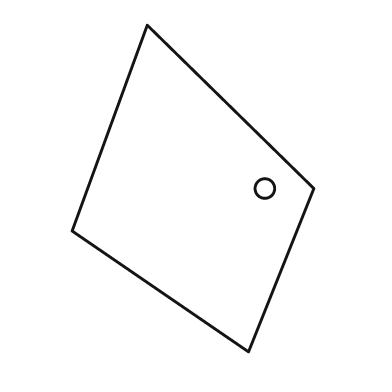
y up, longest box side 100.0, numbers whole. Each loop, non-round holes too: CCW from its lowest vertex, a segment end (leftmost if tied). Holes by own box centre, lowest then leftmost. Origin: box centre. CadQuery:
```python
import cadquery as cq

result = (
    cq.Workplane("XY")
    .moveTo(17.0, -50.0)
    .lineTo(37.0, 0.0)
    .lineTo(-14.0, 50.0)
    .lineTo(-37.0, -13.0)
    .close()
    .moveTo(22.0, 0.0)
    .circle(3.0)
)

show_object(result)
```